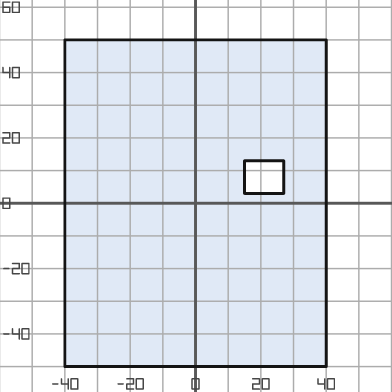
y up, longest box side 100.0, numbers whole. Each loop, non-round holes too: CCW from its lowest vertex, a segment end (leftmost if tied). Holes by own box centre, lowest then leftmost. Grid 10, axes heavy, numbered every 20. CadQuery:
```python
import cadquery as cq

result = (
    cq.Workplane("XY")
    .moveTo(-40.0, -50.0)
    .lineTo(40.0, -50.0)
    .lineTo(40.0, 50.0)
    .lineTo(-40.0, 50.0)
    .close()
    .moveTo(15.0, 3.0)
    .lineTo(27.0, 3.0)
    .lineTo(27.0, 13.0)
    .lineTo(15.0, 13.0)
    .close()
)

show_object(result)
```